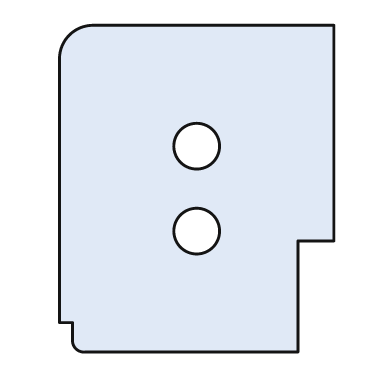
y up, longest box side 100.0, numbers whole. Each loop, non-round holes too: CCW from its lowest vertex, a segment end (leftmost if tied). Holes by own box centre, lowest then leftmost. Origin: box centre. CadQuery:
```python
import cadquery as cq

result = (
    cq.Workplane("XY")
    .moveTo(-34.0, -50.0)
    .lineTo(31.0, -50.0)
    .lineTo(31.0, -16.0)
    .lineTo(42.0, -16.0)
    .lineTo(42.0, 50.0)
    .lineTo(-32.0, 50.0)
    .threePointArc((-39.0, 47.0), (-42.0, 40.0))
    .lineTo(-42.0, -41.0)
    .lineTo(-38.0, -41.0)
    .lineTo(-38.0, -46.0)
    .threePointArc((-37.0, -49.0), (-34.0, -50.0))
    .close()
    .moveTo(0.0, -13.0)
    .circle(7.0)
    .moveTo(0.0, 13.0)
    .circle(7.0)
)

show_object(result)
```